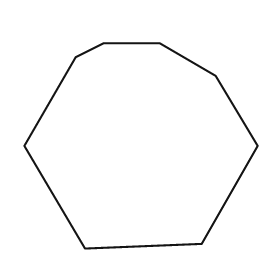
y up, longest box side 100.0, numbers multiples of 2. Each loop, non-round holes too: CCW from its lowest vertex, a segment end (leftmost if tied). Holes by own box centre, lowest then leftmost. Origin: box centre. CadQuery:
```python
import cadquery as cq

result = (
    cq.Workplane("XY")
    .moveTo(-24.0, -44.0)
    .lineTo(26.0, -42.0)
    .lineTo(50.0, 0.0)
    .lineTo(32.0, 30.0)
    .lineTo(8.0, 44.0)
    .lineTo(-16.0, 44.0)
    .lineTo(-28.0, 38.0)
    .lineTo(-50.0, 0.0)
    .close()
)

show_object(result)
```